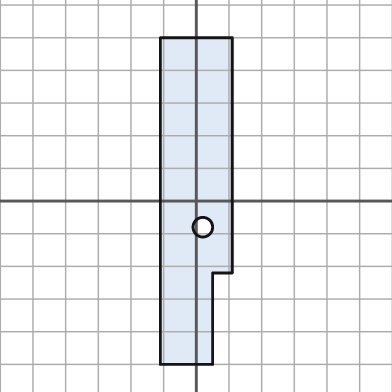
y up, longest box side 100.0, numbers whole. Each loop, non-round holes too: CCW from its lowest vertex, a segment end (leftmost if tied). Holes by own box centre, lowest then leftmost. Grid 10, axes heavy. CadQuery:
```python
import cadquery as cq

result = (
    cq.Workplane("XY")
    .moveTo(-11.0, -50.0)
    .lineTo(5.0, -50.0)
    .lineTo(5.0, -22.0)
    .lineTo(11.0, -22.0)
    .lineTo(11.0, 50.0)
    .lineTo(-11.0, 50.0)
    .close()
    .moveTo(2.0, -8.0)
    .circle(3.0)
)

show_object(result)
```